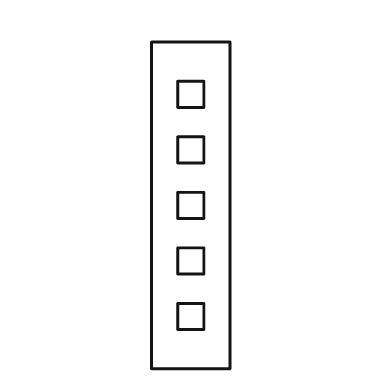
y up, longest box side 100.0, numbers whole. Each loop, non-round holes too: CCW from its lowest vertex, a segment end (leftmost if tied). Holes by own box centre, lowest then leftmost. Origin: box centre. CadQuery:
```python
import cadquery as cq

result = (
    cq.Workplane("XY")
    .moveTo(-12.0, -50.0)
    .lineTo(12.0, -50.0)
    .lineTo(12.0, 50.0)
    .lineTo(-12.0, 50.0)
    .close()
    .moveTo(-4.0, -38.0)
    .lineTo(4.0, -38.0)
    .lineTo(4.0, -30.0)
    .lineTo(-4.0, -30.0)
    .close()
    .moveTo(-4.0, -21.0)
    .lineTo(4.0, -21.0)
    .lineTo(4.0, -13.0)
    .lineTo(-4.0, -13.0)
    .close()
    .moveTo(-4.0, -4.0)
    .lineTo(4.0, -4.0)
    .lineTo(4.0, 4.0)
    .lineTo(-4.0, 4.0)
    .close()
    .moveTo(-4.0, 13.0)
    .lineTo(4.0, 13.0)
    .lineTo(4.0, 21.0)
    .lineTo(-4.0, 21.0)
    .close()
    .moveTo(-4.0, 30.0)
    .lineTo(4.0, 30.0)
    .lineTo(4.0, 38.0)
    .lineTo(-4.0, 38.0)
    .close()
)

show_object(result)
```